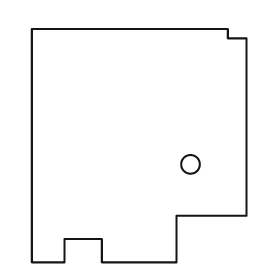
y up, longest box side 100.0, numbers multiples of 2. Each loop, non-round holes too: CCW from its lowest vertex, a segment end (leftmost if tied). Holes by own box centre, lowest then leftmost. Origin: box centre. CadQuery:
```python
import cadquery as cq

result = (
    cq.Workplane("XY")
    .moveTo(-46.0, -50.0)
    .lineTo(-32.0, -50.0)
    .lineTo(-32.0, -40.0)
    .lineTo(-16.0, -40.0)
    .lineTo(-16.0, -50.0)
    .lineTo(16.0, -50.0)
    .lineTo(16.0, -30.0)
    .lineTo(46.0, -30.0)
    .lineTo(46.0, 46.0)
    .lineTo(38.0, 46.0)
    .lineTo(38.0, 50.0)
    .lineTo(-46.0, 50.0)
    .close()
    .moveTo(22.0, -8.0)
    .circle(4.0)
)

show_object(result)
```